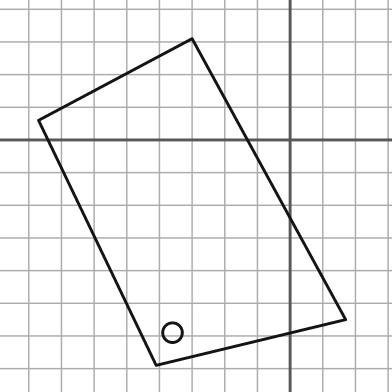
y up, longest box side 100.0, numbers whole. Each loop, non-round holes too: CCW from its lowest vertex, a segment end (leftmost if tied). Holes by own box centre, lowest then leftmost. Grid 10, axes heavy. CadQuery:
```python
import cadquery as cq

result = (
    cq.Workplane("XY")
    .moveTo(-41.0, -69.0)
    .lineTo(17.0, -55.0)
    .lineTo(-30.0, 31.0)
    .lineTo(-77.0, 6.0)
    .close()
    .moveTo(-36.0, -59.0)
    .circle(3.0)
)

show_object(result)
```